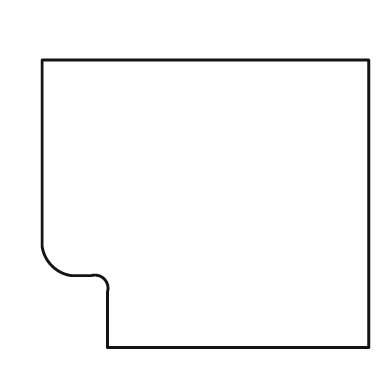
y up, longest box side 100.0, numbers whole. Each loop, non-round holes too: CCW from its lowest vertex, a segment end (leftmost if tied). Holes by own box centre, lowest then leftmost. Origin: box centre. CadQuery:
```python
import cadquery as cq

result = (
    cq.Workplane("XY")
    .moveTo(-30.0, -44.0)
    .lineTo(50.0, -44.0)
    .lineTo(50.0, 44.0)
    .lineTo(-50.0, 44.0)
    .lineTo(-50.0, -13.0)
    .threePointArc((-47.0, -19.0), (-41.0, -22.0))
    .lineTo(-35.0, -22.0)
    .threePointArc((-31.0, -23.0), (-30.0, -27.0))
    .close()
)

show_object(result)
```